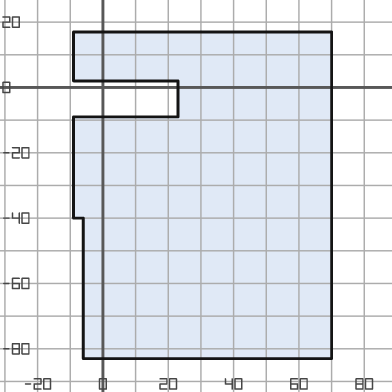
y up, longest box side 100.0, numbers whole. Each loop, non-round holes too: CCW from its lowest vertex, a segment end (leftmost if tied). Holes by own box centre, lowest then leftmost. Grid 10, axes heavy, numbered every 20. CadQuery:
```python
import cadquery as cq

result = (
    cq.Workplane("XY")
    .moveTo(-6.0, -83.0)
    .lineTo(70.0, -83.0)
    .lineTo(70.0, 17.0)
    .lineTo(-9.0, 17.0)
    .lineTo(-9.0, 2.0)
    .lineTo(23.0, 2.0)
    .lineTo(23.0, -9.0)
    .lineTo(-9.0, -9.0)
    .lineTo(-9.0, -40.0)
    .lineTo(-6.0, -40.0)
    .close()
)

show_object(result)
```